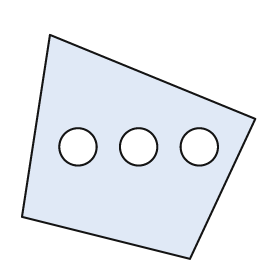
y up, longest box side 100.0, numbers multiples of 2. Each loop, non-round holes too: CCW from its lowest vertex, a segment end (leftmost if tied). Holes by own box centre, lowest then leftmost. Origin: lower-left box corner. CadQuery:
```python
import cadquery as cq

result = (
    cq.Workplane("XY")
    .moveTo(72.0, 0.0)
    .lineTo(100.0, 60.0)
    .lineTo(12.0, 96.0)
    .lineTo(0.0, 18.0)
    .close()
    .moveTo(24.0, 48.0)
    .circle(8.0)
    .moveTo(50.0, 48.0)
    .circle(8.0)
    .moveTo(76.0, 48.0)
    .circle(8.0)
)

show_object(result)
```